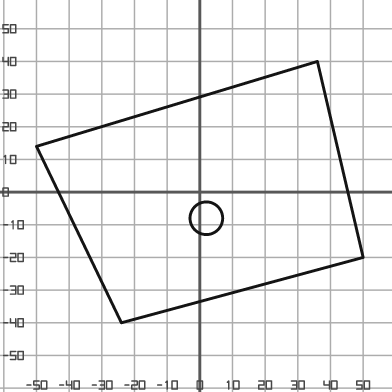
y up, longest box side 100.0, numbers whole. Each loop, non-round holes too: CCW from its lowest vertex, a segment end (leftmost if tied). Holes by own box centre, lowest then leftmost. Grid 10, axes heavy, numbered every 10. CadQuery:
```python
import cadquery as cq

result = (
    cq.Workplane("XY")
    .moveTo(-24.0, -40.0)
    .lineTo(50.0, -20.0)
    .lineTo(36.0, 40.0)
    .lineTo(-50.0, 14.0)
    .close()
    .moveTo(2.0, -8.0)
    .circle(5.0)
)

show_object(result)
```